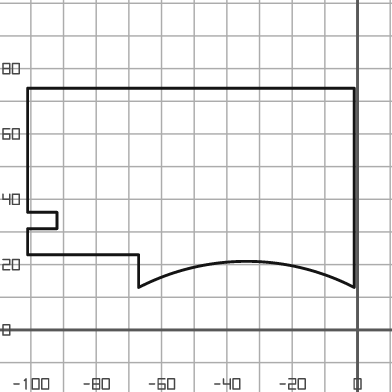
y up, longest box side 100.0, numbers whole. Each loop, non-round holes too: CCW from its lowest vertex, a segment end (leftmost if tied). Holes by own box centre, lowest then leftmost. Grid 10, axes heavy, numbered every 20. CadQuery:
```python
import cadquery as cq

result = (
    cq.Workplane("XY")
    .moveTo(-67.0, 13.0)
    .threePointArc((-34.0, 21.0), (-1.0, 13.0))
    .lineTo(-1.0, 74.0)
    .lineTo(-101.0, 74.0)
    .lineTo(-101.0, 36.0)
    .lineTo(-92.0, 36.0)
    .lineTo(-92.0, 31.0)
    .lineTo(-101.0, 31.0)
    .lineTo(-101.0, 23.0)
    .lineTo(-67.0, 23.0)
    .close()
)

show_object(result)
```